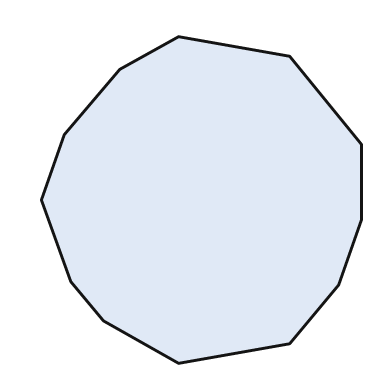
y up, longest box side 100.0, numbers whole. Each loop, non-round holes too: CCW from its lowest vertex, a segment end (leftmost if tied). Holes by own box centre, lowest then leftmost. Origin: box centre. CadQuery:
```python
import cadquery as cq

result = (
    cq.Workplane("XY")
    .moveTo(-7.0, -50.0)
    .lineTo(27.0, -44.0)
    .lineTo(42.0, -26.0)
    .lineTo(49.0, -6.0)
    .lineTo(49.0, 17.0)
    .lineTo(27.0, 44.0)
    .lineTo(-7.0, 50.0)
    .lineTo(-25.0, 40.0)
    .lineTo(-42.0, 20.0)
    .lineTo(-49.0, 0.0)
    .lineTo(-40.0, -25.0)
    .lineTo(-30.0, -37.0)
    .close()
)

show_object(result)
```